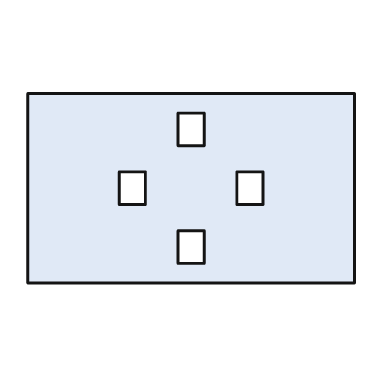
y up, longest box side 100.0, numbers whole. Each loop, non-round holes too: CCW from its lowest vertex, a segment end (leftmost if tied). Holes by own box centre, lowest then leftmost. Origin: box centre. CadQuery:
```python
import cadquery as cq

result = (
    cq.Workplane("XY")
    .moveTo(-50.0, -29.0)
    .lineTo(50.0, -29.0)
    .lineTo(50.0, 29.0)
    .lineTo(-50.0, 29.0)
    .close()
    .moveTo(-4.0, -23.0)
    .lineTo(4.0, -23.0)
    .lineTo(4.0, -13.0)
    .lineTo(-4.0, -13.0)
    .close()
    .moveTo(-22.0, -5.0)
    .lineTo(-14.0, -5.0)
    .lineTo(-14.0, 5.0)
    .lineTo(-22.0, 5.0)
    .close()
    .moveTo(14.0, -5.0)
    .lineTo(22.0, -5.0)
    .lineTo(22.0, 5.0)
    .lineTo(14.0, 5.0)
    .close()
    .moveTo(-4.0, 13.0)
    .lineTo(4.0, 13.0)
    .lineTo(4.0, 23.0)
    .lineTo(-4.0, 23.0)
    .close()
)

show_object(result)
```